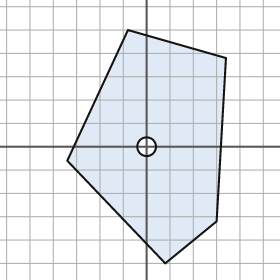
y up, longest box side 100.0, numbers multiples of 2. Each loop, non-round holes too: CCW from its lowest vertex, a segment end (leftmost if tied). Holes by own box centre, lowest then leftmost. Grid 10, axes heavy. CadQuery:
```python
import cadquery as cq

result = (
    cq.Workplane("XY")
    .moveTo(8.0, -50.0)
    .lineTo(30.0, -32.0)
    .lineTo(34.0, 38.0)
    .lineTo(-8.0, 50.0)
    .lineTo(-34.0, -6.0)
    .close()
    .moveTo(0.0, 0.0)
    .circle(4.0)
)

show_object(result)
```